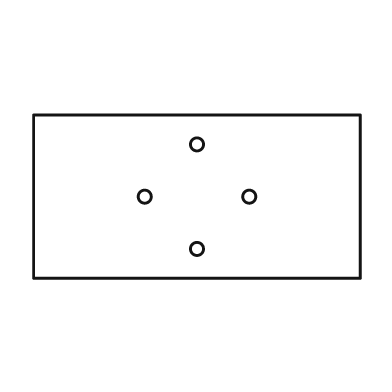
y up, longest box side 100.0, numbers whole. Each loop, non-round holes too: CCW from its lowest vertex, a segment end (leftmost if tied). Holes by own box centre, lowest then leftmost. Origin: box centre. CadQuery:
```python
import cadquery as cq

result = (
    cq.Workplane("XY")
    .moveTo(-50.0, -25.0)
    .lineTo(50.0, -25.0)
    .lineTo(50.0, 25.0)
    .lineTo(-50.0, 25.0)
    .close()
    .moveTo(0.0, -16.0)
    .circle(2.0)
    .moveTo(-16.0, 0.0)
    .circle(2.0)
    .moveTo(16.0, 0.0)
    .circle(2.0)
    .moveTo(0.0, 16.0)
    .circle(2.0)
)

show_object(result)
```